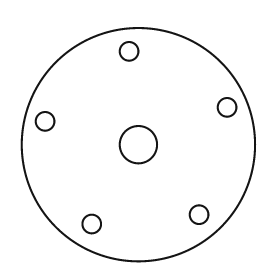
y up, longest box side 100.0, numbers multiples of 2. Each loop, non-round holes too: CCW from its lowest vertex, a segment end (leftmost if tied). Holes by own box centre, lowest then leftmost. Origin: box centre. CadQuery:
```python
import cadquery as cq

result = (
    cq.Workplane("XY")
    .moveTo(0.0, 0.0)
    .circle(50.0)
    .moveTo(-20.0, -34.0)
    .circle(4.0)
    .moveTo(26.0, -30.0)
    .circle(4.0)
    .moveTo(0.0, 0.0)
    .circle(8.0)
    .moveTo(-40.0, 10.0)
    .circle(4.0)
    .moveTo(38.0, 16.0)
    .circle(4.0)
    .moveTo(-4.0, 40.0)
    .circle(4.0)
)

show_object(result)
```